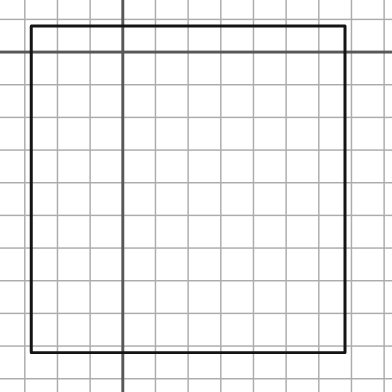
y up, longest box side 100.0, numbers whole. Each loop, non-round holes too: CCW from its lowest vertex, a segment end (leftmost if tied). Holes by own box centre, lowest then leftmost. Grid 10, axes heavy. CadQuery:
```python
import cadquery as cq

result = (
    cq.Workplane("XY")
    .moveTo(-28.0, -92.0)
    .lineTo(68.0, -92.0)
    .lineTo(68.0, 8.0)
    .lineTo(-28.0, 8.0)
    .close()
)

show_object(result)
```